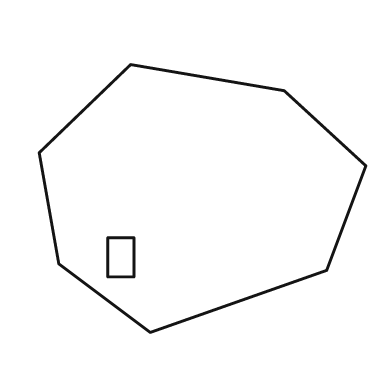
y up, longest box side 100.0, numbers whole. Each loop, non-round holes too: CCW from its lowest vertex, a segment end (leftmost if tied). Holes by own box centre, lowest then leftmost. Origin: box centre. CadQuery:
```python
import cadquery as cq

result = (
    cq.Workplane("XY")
    .moveTo(-16.0, -41.0)
    .lineTo(38.0, -22.0)
    .lineTo(50.0, 10.0)
    .lineTo(25.0, 33.0)
    .lineTo(-22.0, 41.0)
    .lineTo(-50.0, 14.0)
    .lineTo(-44.0, -20.0)
    .close()
    .moveTo(-29.0, -24.0)
    .lineTo(-21.0, -24.0)
    .lineTo(-21.0, -12.0)
    .lineTo(-29.0, -12.0)
    .close()
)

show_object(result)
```